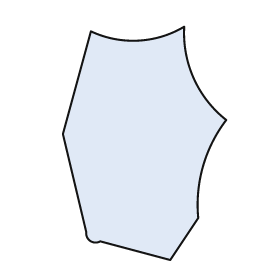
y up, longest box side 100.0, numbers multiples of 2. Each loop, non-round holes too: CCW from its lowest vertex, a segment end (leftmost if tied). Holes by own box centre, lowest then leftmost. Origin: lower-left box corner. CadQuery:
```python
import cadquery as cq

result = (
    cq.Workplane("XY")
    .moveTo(46.0, 0.0)
    .lineTo(58.0, 18.0)
    .threePointArc((60.0, 40.0), (70.0, 60.0))
    .threePointArc((56.0, 78.0), (52.0, 100.0))
    .threePointArc((32.0, 94.0), (12.0, 98.0))
    .lineTo(0.0, 54.0)
    .lineTo(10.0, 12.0)
    .threePointArc((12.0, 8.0), (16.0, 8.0))
    .close()
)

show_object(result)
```